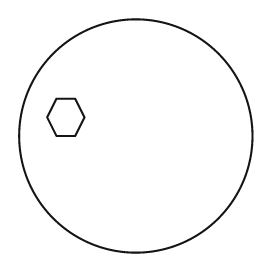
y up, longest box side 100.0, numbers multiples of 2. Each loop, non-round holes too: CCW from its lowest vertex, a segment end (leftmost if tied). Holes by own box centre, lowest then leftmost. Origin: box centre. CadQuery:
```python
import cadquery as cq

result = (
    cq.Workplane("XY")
    .moveTo(0.0, 0.0)
    .circle(50.0)
    .moveTo(-34.0, 0.0)
    .lineTo(-26.0, 0.0)
    .lineTo(-22.0, 8.0)
    .lineTo(-26.0, 16.0)
    .lineTo(-34.0, 16.0)
    .lineTo(-38.0, 8.0)
    .close()
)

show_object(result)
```